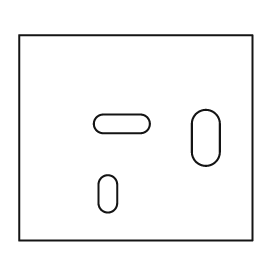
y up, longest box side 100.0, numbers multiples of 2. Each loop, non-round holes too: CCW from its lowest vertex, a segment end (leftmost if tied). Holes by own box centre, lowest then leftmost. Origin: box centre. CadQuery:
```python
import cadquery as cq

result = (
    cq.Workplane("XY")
    .moveTo(-50.0, -44.0)
    .lineTo(50.0, -44.0)
    .lineTo(50.0, 44.0)
    .lineTo(-50.0, 44.0)
    .close()
    .moveTo(-16.0, -28.0)
    .threePointArc((-12.0, -32.0), (-8.0, -28.0))
    .lineTo(-8.0, -20.0)
    .threePointArc((-12.0, -16.0), (-16.0, -20.0))
    .close()
    .moveTo(24.0, -6.0)
    .threePointArc((30.0, -12.0), (36.0, -6.0))
    .lineTo(36.0, 6.0)
    .threePointArc((30.0, 12.0), (24.0, 6.0))
    .close()
    .moveTo(-14.0, 2.0)
    .lineTo(2.0, 2.0)
    .threePointArc((6.0, 6.0), (2.0, 10.0))
    .lineTo(-14.0, 10.0)
    .threePointArc((-18.0, 6.0), (-14.0, 2.0))
    .close()
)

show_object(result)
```